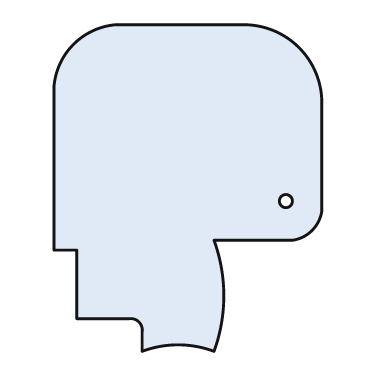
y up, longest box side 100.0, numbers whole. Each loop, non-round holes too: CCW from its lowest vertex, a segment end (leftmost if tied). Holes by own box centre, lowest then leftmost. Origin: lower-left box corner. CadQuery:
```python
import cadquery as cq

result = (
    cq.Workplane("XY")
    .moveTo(27.0, 0.0)
    .threePointArc((38.0, 2.0), (49.0, 0.0))
    .threePointArc((52.0, 17.0), (49.0, 34.0))
    .lineTo(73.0, 34.0)
    .threePointArc((79.0, 37.0), (82.0, 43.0))
    .lineTo(82.0, 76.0)
    .threePointArc((75.0, 93.0), (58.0, 100.0))
    .lineTo(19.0, 100.0)
    .threePointArc((6.0, 94.0), (0.0, 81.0))
    .lineTo(0.0, 31.0)
    .lineTo(7.0, 31.0)
    .lineTo(7.0, 10.0)
    .lineTo(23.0, 10.0)
    .threePointArc((26.0, 9.0), (27.0, 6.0))
    .close()
    .moveTo(71.0, 46.0)
    .circle(2.0)
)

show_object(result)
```